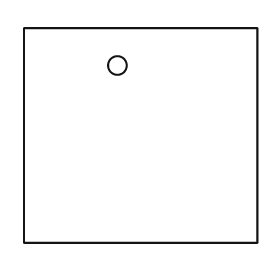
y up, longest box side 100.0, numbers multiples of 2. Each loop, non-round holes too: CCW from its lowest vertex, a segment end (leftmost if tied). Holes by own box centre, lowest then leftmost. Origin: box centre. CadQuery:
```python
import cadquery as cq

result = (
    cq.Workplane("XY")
    .moveTo(-50.0, -46.0)
    .lineTo(50.0, -46.0)
    .lineTo(50.0, 46.0)
    .lineTo(-50.0, 46.0)
    .close()
    .moveTo(-10.0, 30.0)
    .circle(4.0)
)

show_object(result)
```